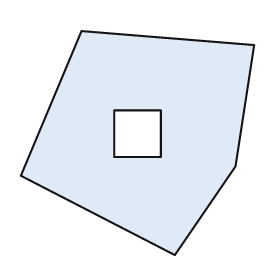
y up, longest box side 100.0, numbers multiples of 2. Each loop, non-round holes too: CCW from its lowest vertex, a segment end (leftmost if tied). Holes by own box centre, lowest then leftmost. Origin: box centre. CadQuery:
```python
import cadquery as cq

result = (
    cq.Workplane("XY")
    .moveTo(16.0, -48.0)
    .lineTo(42.0, -10.0)
    .lineTo(50.0, 42.0)
    .lineTo(-24.0, 48.0)
    .lineTo(-50.0, -14.0)
    .close()
    .moveTo(-10.0, -6.0)
    .lineTo(10.0, -6.0)
    .lineTo(10.0, 14.0)
    .lineTo(-10.0, 14.0)
    .close()
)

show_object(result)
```